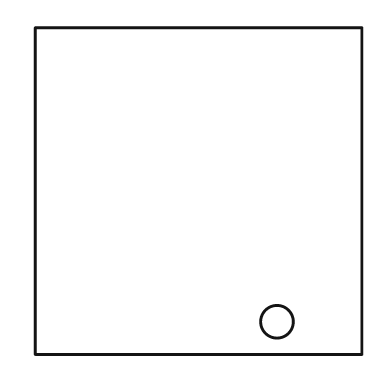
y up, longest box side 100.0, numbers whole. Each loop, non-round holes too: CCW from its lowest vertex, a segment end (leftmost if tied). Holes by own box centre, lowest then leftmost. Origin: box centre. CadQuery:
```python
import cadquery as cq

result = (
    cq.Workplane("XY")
    .moveTo(-50.0, -50.0)
    .lineTo(50.0, -50.0)
    .lineTo(50.0, 50.0)
    .lineTo(-50.0, 50.0)
    .close()
    .moveTo(24.0, -40.0)
    .circle(5.0)
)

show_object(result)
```